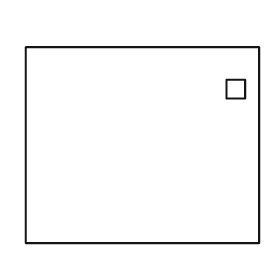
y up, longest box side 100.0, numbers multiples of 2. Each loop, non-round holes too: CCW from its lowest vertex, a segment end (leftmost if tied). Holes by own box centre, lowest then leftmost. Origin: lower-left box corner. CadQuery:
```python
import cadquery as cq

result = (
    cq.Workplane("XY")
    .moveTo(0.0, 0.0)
    .lineTo(100.0, 0.0)
    .lineTo(100.0, 84.0)
    .lineTo(0.0, 84.0)
    .close()
    .moveTo(86.0, 62.0)
    .lineTo(94.0, 62.0)
    .lineTo(94.0, 70.0)
    .lineTo(86.0, 70.0)
    .close()
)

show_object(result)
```